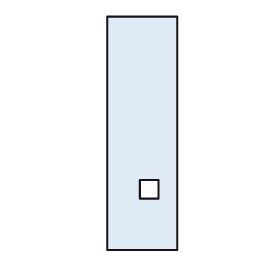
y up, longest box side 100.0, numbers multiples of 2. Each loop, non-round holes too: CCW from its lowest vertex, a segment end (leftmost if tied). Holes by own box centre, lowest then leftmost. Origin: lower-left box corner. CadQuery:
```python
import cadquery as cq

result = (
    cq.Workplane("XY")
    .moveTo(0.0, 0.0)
    .lineTo(30.0, 0.0)
    .lineTo(30.0, 100.0)
    .lineTo(0.0, 100.0)
    .close()
    .moveTo(14.0, 22.0)
    .lineTo(22.0, 22.0)
    .lineTo(22.0, 30.0)
    .lineTo(14.0, 30.0)
    .close()
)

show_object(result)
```